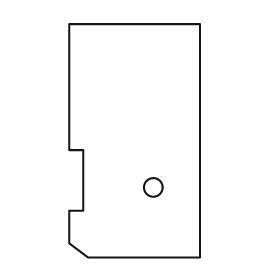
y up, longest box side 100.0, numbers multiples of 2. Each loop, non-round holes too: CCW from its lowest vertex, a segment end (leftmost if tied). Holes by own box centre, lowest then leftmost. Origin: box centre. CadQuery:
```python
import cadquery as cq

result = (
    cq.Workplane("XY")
    .moveTo(-20.0, -50.0)
    .lineTo(28.0, -50.0)
    .lineTo(28.0, 50.0)
    .lineTo(-28.0, 50.0)
    .lineTo(-28.0, -4.0)
    .lineTo(-22.0, -4.0)
    .lineTo(-22.0, -30.0)
    .lineTo(-28.0, -30.0)
    .lineTo(-28.0, -44.0)
    .close()
    .moveTo(8.0, -20.0)
    .circle(4.0)
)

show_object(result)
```